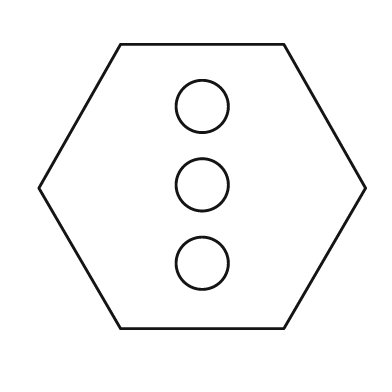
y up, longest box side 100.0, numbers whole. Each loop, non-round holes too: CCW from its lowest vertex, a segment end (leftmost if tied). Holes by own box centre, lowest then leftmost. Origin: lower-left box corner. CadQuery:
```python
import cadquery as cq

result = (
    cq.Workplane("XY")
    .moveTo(25.0, 0.0)
    .lineTo(75.0, 0.0)
    .lineTo(100.0, 43.0)
    .lineTo(75.0, 87.0)
    .lineTo(25.0, 87.0)
    .lineTo(0.0, 43.0)
    .close()
    .moveTo(50.0, 20.0)
    .circle(8.0)
    .moveTo(50.0, 44.0)
    .circle(8.0)
    .moveTo(50.0, 68.0)
    .circle(8.0)
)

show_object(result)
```